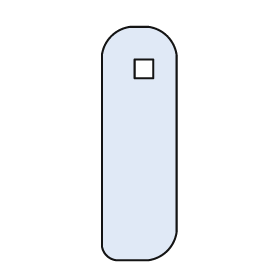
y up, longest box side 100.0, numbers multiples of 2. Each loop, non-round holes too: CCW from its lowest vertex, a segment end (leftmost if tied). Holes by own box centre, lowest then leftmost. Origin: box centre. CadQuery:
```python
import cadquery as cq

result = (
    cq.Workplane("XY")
    .moveTo(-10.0, -50.0)
    .lineTo(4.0, -50.0)
    .threePointArc((12.0, -46.0), (16.0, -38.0))
    .lineTo(16.0, 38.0)
    .threePointArc((12.0, 46.0), (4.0, 50.0))
    .lineTo(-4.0, 50.0)
    .threePointArc((-12.0, 46.0), (-16.0, 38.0))
    .lineTo(-16.0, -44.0)
    .threePointArc((-14.0, -48.0), (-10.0, -50.0))
    .close()
    .moveTo(-2.0, 28.0)
    .lineTo(6.0, 28.0)
    .lineTo(6.0, 36.0)
    .lineTo(-2.0, 36.0)
    .close()
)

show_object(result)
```